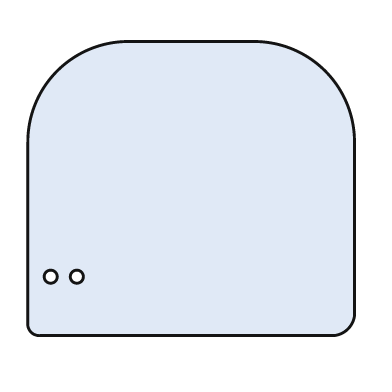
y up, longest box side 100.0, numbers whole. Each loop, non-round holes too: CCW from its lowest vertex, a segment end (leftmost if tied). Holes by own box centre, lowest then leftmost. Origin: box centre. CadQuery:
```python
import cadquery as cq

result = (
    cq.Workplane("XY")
    .moveTo(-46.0, -45.0)
    .lineTo(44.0, -45.0)
    .threePointArc((48.0, -43.0), (50.0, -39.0))
    .lineTo(50.0, 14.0)
    .threePointArc((41.0, 36.0), (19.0, 45.0))
    .lineTo(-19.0, 45.0)
    .threePointArc((-41.0, 36.0), (-50.0, 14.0))
    .lineTo(-50.0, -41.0)
    .threePointArc((-49.0, -44.0), (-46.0, -45.0))
    .close()
    .moveTo(-43.0, -27.0)
    .circle(2.0)
    .moveTo(-35.0, -27.0)
    .circle(2.0)
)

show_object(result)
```